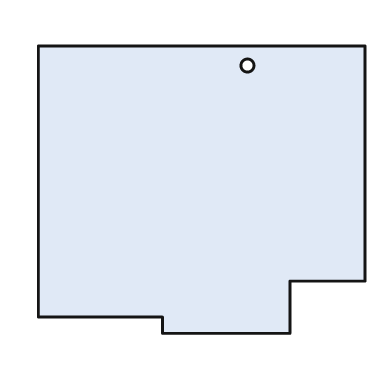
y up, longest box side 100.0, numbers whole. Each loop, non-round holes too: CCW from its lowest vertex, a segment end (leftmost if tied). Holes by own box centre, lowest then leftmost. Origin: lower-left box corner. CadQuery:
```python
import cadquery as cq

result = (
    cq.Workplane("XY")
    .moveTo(38.0, 0.0)
    .lineTo(77.0, 0.0)
    .lineTo(77.0, 16.0)
    .lineTo(100.0, 16.0)
    .lineTo(100.0, 88.0)
    .lineTo(0.0, 88.0)
    .lineTo(0.0, 5.0)
    .lineTo(38.0, 5.0)
    .close()
    .moveTo(64.0, 82.0)
    .circle(2.0)
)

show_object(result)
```